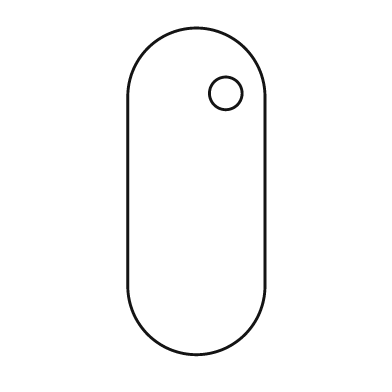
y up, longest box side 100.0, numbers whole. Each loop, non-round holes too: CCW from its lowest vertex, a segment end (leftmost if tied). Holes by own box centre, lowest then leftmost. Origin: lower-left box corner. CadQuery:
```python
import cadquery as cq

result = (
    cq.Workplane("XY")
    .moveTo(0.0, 21.0)
    .threePointArc((21.0, 0.0), (42.0, 21.0))
    .lineTo(42.0, 79.0)
    .threePointArc((21.0, 100.0), (0.0, 79.0))
    .close()
    .moveTo(30.0, 80.0)
    .circle(5.0)
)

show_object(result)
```